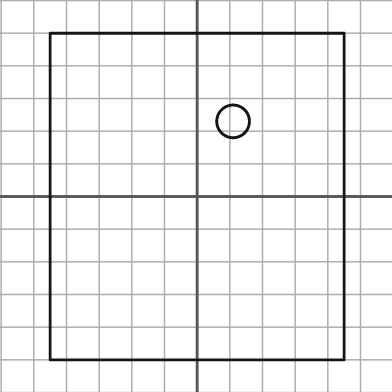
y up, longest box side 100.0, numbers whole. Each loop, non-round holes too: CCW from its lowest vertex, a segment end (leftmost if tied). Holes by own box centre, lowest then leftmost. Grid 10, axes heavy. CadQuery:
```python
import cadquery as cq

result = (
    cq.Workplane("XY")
    .moveTo(-45.0, -50.0)
    .lineTo(45.0, -50.0)
    .lineTo(45.0, 50.0)
    .lineTo(-45.0, 50.0)
    .close()
    .moveTo(11.0, 23.0)
    .circle(5.0)
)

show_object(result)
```